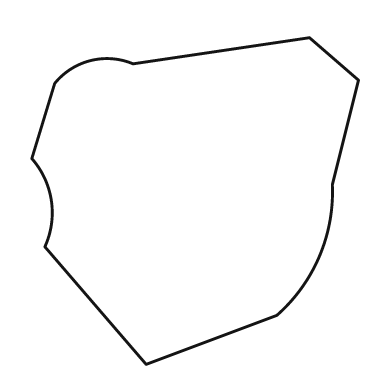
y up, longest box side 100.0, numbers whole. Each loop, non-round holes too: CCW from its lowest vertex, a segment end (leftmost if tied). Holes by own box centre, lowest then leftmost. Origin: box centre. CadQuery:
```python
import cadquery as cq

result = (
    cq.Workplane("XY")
    .moveTo(-15.0, -50.0)
    .lineTo(25.0, -35.0)
    .threePointArc((38.0, -17.0), (42.0, 5.0))
    .lineTo(50.0, 37.0)
    .lineTo(35.0, 50.0)
    .lineTo(-19.0, 42.0)
    .threePointArc((-32.0, 43.0), (-43.0, 36.0))
    .lineTo(-50.0, 13.0)
    .threePointArc((-44.0, 0.0), (-46.0, -14.0))
    .close()
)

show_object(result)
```